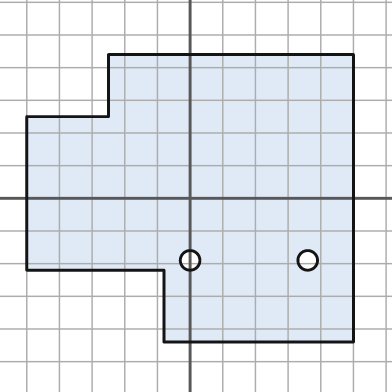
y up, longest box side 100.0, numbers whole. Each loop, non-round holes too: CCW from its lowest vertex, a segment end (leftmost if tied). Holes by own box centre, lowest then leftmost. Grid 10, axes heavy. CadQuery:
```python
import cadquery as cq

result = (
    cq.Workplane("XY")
    .moveTo(-8.0, -44.0)
    .lineTo(50.0, -44.0)
    .lineTo(50.0, 44.0)
    .lineTo(-25.0, 44.0)
    .lineTo(-25.0, 25.0)
    .lineTo(-50.0, 25.0)
    .lineTo(-50.0, -22.0)
    .lineTo(-8.0, -22.0)
    .close()
    .moveTo(0.0, -19.0)
    .circle(3.0)
    .moveTo(36.0, -19.0)
    .circle(3.0)
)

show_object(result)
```